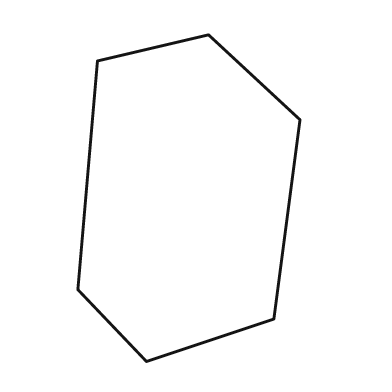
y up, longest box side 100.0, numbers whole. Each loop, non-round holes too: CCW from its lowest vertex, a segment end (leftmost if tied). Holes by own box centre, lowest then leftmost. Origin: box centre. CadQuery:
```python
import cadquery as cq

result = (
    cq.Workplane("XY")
    .moveTo(-13.0, -50.0)
    .lineTo(26.0, -37.0)
    .lineTo(34.0, 24.0)
    .lineTo(6.0, 50.0)
    .lineTo(-28.0, 42.0)
    .lineTo(-34.0, -28.0)
    .close()
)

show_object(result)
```